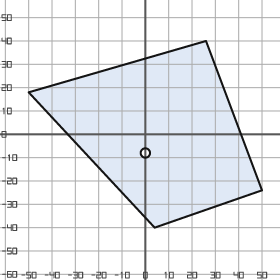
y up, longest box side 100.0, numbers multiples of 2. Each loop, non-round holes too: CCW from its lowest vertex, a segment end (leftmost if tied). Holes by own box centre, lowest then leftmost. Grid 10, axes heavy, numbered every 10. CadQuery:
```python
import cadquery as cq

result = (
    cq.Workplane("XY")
    .moveTo(4.0, -40.0)
    .lineTo(50.0, -24.0)
    .lineTo(26.0, 40.0)
    .lineTo(-50.0, 18.0)
    .close()
    .moveTo(0.0, -8.0)
    .circle(2.0)
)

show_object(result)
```